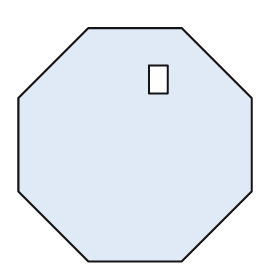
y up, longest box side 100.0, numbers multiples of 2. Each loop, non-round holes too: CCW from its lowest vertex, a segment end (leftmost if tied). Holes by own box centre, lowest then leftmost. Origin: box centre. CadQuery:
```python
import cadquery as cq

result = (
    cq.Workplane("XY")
    .moveTo(-20.0, -50.0)
    .lineTo(20.0, -50.0)
    .lineTo(50.0, -20.0)
    .lineTo(50.0, 20.0)
    .lineTo(20.0, 50.0)
    .lineTo(-20.0, 50.0)
    .lineTo(-50.0, 20.0)
    .lineTo(-50.0, -20.0)
    .close()
    .moveTo(6.0, 22.0)
    .lineTo(14.0, 22.0)
    .lineTo(14.0, 34.0)
    .lineTo(6.0, 34.0)
    .close()
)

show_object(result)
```